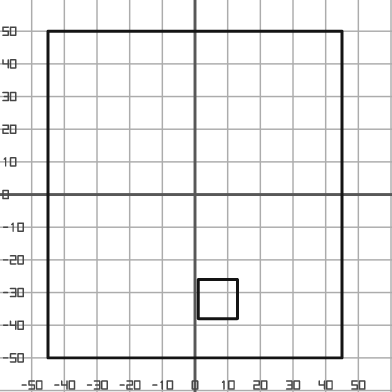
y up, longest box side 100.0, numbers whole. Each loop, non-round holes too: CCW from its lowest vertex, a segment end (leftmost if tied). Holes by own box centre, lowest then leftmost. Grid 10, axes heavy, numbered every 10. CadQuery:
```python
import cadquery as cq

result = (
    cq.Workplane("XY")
    .moveTo(-45.0, -50.0)
    .lineTo(45.0, -50.0)
    .lineTo(45.0, 50.0)
    .lineTo(-45.0, 50.0)
    .close()
    .moveTo(1.0, -38.0)
    .lineTo(13.0, -38.0)
    .lineTo(13.0, -26.0)
    .lineTo(1.0, -26.0)
    .close()
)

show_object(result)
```